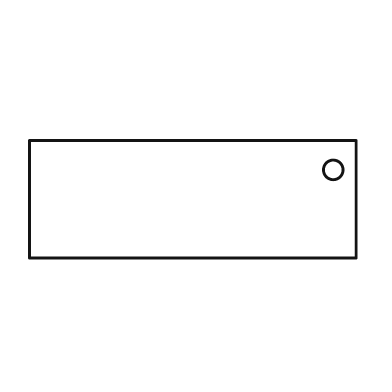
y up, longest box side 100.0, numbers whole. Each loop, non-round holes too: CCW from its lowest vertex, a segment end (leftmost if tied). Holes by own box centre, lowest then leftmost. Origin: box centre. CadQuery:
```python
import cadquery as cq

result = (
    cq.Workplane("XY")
    .moveTo(-50.0, -18.0)
    .lineTo(50.0, -18.0)
    .lineTo(50.0, 18.0)
    .lineTo(-50.0, 18.0)
    .close()
    .moveTo(43.0, 9.0)
    .circle(3.0)
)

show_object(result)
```